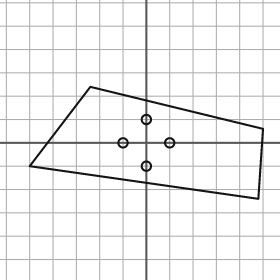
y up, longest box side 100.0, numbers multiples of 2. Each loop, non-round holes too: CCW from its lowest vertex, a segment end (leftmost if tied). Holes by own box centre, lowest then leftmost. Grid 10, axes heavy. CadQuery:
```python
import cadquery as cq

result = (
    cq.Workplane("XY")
    .moveTo(48.0, -24.0)
    .lineTo(50.0, 6.0)
    .lineTo(-24.0, 24.0)
    .lineTo(-50.0, -10.0)
    .close()
    .moveTo(0.0, -10.0)
    .circle(2.0)
    .moveTo(-10.0, 0.0)
    .circle(2.0)
    .moveTo(10.0, 0.0)
    .circle(2.0)
    .moveTo(0.0, 10.0)
    .circle(2.0)
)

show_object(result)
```